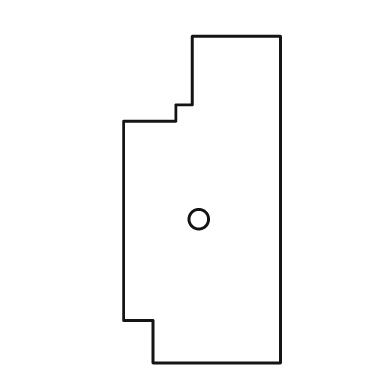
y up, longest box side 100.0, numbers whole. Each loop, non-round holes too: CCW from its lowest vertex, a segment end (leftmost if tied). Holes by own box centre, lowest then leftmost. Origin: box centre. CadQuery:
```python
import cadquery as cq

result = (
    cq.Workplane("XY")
    .moveTo(-15.0, -50.0)
    .lineTo(24.0, -50.0)
    .lineTo(24.0, 50.0)
    .lineTo(-3.0, 50.0)
    .lineTo(-3.0, 29.0)
    .lineTo(-8.0, 29.0)
    .lineTo(-8.0, 24.0)
    .lineTo(-24.0, 24.0)
    .lineTo(-24.0, -37.0)
    .lineTo(-15.0, -37.0)
    .close()
    .moveTo(-1.0, -6.0)
    .circle(3.0)
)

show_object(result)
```